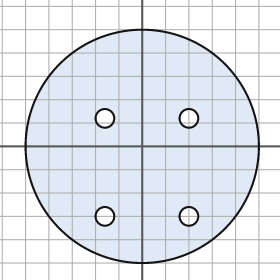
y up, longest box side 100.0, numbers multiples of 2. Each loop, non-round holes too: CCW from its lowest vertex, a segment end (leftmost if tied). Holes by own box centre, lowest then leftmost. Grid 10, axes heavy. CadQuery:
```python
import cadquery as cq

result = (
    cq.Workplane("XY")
    .moveTo(0.0, 0.0)
    .circle(50.0)
    .moveTo(-16.0, -30.0)
    .circle(4.0)
    .moveTo(20.0, -30.0)
    .circle(4.0)
    .moveTo(-16.0, 12.0)
    .circle(4.0)
    .moveTo(20.0, 12.0)
    .circle(4.0)
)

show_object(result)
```